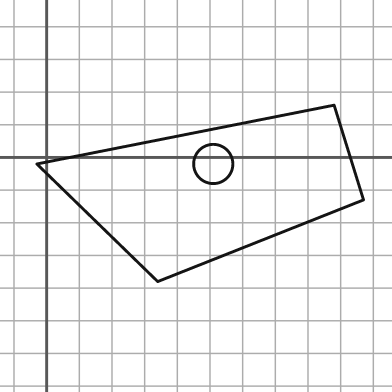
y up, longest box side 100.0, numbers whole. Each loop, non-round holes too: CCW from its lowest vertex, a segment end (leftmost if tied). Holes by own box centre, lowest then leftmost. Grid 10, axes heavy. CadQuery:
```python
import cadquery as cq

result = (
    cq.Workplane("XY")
    .moveTo(34.0, -38.0)
    .lineTo(97.0, -13.0)
    .lineTo(88.0, 16.0)
    .lineTo(-3.0, -2.0)
    .close()
    .moveTo(51.0, -2.0)
    .circle(6.0)
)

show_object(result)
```